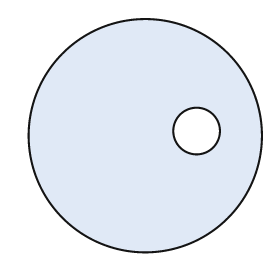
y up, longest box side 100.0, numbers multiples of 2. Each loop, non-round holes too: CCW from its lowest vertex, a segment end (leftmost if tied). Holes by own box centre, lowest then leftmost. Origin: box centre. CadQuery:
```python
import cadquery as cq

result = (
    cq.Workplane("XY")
    .moveTo(0.0, 0.0)
    .circle(50.0)
    .moveTo(22.0, 2.0)
    .circle(10.0)
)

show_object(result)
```